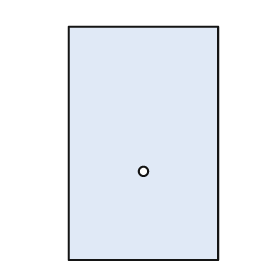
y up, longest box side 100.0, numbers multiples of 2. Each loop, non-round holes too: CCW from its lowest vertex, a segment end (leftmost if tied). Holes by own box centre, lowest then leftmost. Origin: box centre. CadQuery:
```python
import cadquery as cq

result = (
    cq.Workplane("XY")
    .moveTo(-32.0, -50.0)
    .lineTo(32.0, -50.0)
    .lineTo(32.0, 50.0)
    .lineTo(-32.0, 50.0)
    .close()
    .moveTo(0.0, -12.0)
    .circle(2.0)
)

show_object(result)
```